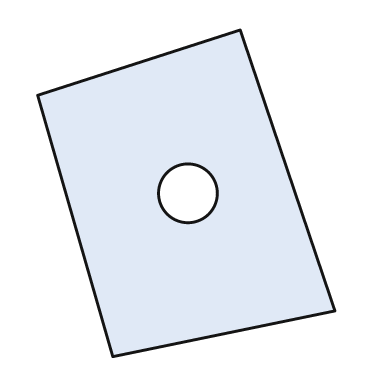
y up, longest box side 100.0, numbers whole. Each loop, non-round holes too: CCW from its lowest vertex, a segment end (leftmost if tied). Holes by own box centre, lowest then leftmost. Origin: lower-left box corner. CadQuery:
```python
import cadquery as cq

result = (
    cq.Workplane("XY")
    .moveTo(23.0, 0.0)
    .lineTo(91.0, 14.0)
    .lineTo(62.0, 100.0)
    .lineTo(0.0, 80.0)
    .close()
    .moveTo(46.0, 50.0)
    .circle(9.0)
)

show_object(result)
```